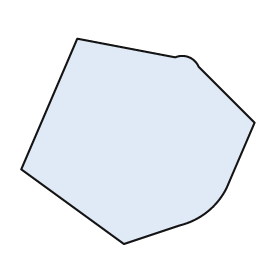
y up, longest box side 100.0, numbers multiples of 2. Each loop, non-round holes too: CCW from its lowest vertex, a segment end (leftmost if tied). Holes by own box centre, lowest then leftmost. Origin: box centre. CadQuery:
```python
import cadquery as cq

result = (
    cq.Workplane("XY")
    .moveTo(-6.0, -44.0)
    .lineTo(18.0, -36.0)
    .threePointArc((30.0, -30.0), (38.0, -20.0))
    .lineTo(50.0, 8.0)
    .lineTo(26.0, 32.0)
    .threePointArc((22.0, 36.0), (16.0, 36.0))
    .lineTo(-26.0, 44.0)
    .lineTo(-50.0, -12.0)
    .close()
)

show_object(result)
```